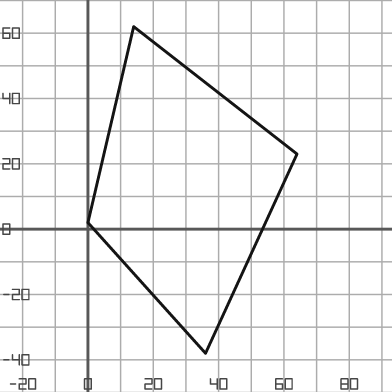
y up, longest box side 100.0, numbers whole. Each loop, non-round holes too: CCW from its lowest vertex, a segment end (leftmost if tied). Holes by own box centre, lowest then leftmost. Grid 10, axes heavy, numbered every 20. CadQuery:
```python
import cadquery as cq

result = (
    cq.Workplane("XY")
    .moveTo(36.0, -38.0)
    .lineTo(64.0, 23.0)
    .lineTo(14.0, 62.0)
    .lineTo(0.0, 2.0)
    .close()
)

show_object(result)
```